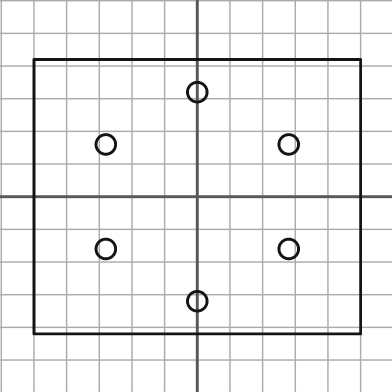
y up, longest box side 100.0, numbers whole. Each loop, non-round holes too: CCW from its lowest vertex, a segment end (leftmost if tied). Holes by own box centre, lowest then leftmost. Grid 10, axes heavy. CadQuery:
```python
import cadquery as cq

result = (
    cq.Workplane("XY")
    .moveTo(-50.0, -42.0)
    .lineTo(50.0, -42.0)
    .lineTo(50.0, 42.0)
    .lineTo(-50.0, 42.0)
    .close()
    .moveTo(0.0, -32.0)
    .circle(3.0)
    .moveTo(-28.0, -16.0)
    .circle(3.0)
    .moveTo(28.0, -16.0)
    .circle(3.0)
    .moveTo(-28.0, 16.0)
    .circle(3.0)
    .moveTo(28.0, 16.0)
    .circle(3.0)
    .moveTo(0.0, 32.0)
    .circle(3.0)
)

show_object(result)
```